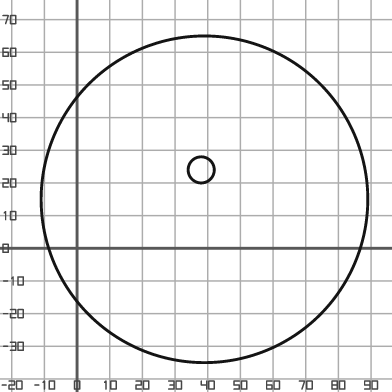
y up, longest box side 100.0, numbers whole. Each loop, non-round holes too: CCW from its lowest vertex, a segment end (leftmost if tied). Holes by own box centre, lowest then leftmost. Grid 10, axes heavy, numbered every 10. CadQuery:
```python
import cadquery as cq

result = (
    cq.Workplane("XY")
    .moveTo(39.0, 15.0)
    .circle(50.0)
    .moveTo(38.0, 24.0)
    .circle(4.0)
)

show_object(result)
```